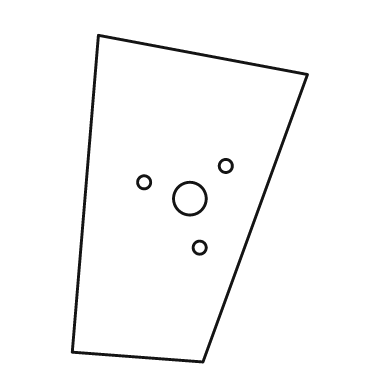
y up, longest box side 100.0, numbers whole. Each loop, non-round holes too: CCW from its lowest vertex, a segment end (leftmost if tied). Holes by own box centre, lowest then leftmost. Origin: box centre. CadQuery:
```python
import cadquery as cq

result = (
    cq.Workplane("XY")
    .moveTo(4.0, -50.0)
    .lineTo(36.0, 38.0)
    .lineTo(-28.0, 50.0)
    .lineTo(-36.0, -47.0)
    .close()
    .moveTo(3.0, -15.0)
    .circle(2.0)
    .moveTo(0.0, 0.0)
    .circle(5.0)
    .moveTo(-14.0, 5.0)
    .circle(2.0)
    .moveTo(11.0, 10.0)
    .circle(2.0)
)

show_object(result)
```